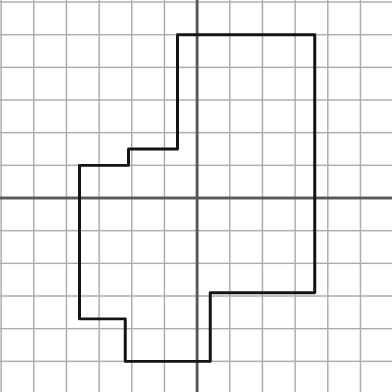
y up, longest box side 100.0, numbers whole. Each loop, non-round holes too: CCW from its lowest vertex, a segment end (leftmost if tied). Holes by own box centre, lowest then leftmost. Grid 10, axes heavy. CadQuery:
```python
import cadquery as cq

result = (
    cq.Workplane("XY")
    .moveTo(-22.0, -50.0)
    .lineTo(4.0, -50.0)
    .lineTo(4.0, -29.0)
    .lineTo(36.0, -29.0)
    .lineTo(36.0, 50.0)
    .lineTo(-6.0, 50.0)
    .lineTo(-6.0, 15.0)
    .lineTo(-21.0, 15.0)
    .lineTo(-21.0, 10.0)
    .lineTo(-36.0, 10.0)
    .lineTo(-36.0, -37.0)
    .lineTo(-22.0, -37.0)
    .close()
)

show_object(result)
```